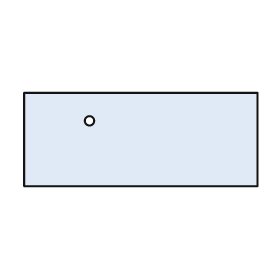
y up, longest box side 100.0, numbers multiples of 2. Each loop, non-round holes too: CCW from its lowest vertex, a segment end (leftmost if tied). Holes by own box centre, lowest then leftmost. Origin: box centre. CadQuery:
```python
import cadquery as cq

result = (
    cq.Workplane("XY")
    .moveTo(-50.0, -20.0)
    .lineTo(50.0, -20.0)
    .lineTo(50.0, 20.0)
    .lineTo(-50.0, 20.0)
    .close()
    .moveTo(-22.0, 8.0)
    .circle(2.0)
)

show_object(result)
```